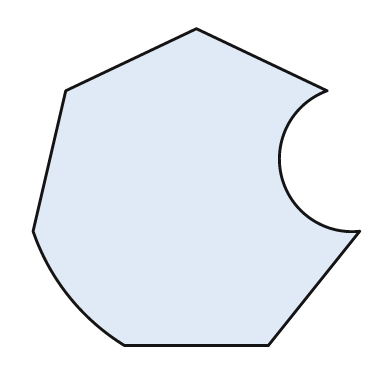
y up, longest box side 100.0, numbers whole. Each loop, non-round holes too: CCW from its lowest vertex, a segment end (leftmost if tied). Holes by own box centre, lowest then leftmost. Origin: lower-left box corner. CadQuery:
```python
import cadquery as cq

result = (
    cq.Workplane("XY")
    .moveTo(28.0, 0.0)
    .lineTo(72.0, 0.0)
    .lineTo(100.0, 35.0)
    .threePointArc((76.0, 52.0), (90.0, 78.0))
    .lineTo(50.0, 97.0)
    .lineTo(10.0, 78.0)
    .lineTo(0.0, 35.0)
    .threePointArc((11.0, 15.0), (28.0, 0.0))
    .close()
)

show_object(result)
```